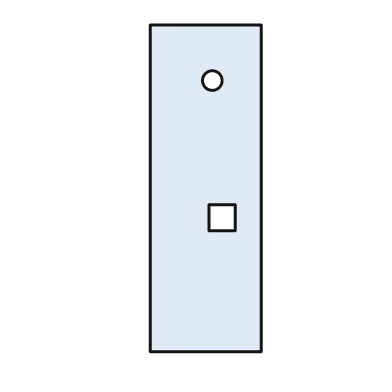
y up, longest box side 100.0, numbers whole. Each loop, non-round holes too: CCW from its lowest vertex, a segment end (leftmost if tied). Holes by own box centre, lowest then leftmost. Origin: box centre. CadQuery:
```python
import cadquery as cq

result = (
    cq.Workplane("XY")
    .moveTo(-17.0, -50.0)
    .lineTo(17.0, -50.0)
    .lineTo(17.0, 50.0)
    .lineTo(-17.0, 50.0)
    .close()
    .moveTo(1.0, -13.0)
    .lineTo(9.0, -13.0)
    .lineTo(9.0, -5.0)
    .lineTo(1.0, -5.0)
    .close()
    .moveTo(2.0, 33.0)
    .circle(3.0)
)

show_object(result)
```